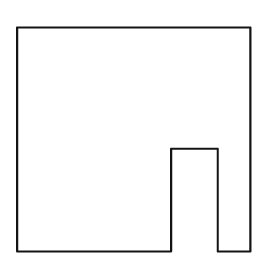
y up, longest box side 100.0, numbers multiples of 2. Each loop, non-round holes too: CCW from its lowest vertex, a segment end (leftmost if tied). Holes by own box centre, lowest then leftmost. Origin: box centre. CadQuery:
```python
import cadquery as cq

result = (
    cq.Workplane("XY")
    .moveTo(-50.0, -48.0)
    .lineTo(16.0, -48.0)
    .lineTo(16.0, -4.0)
    .lineTo(36.0, -4.0)
    .lineTo(36.0, -48.0)
    .lineTo(50.0, -48.0)
    .lineTo(50.0, 48.0)
    .lineTo(-50.0, 48.0)
    .close()
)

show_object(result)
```